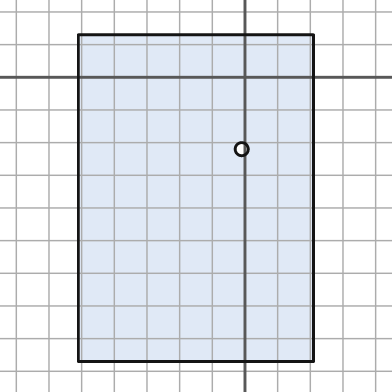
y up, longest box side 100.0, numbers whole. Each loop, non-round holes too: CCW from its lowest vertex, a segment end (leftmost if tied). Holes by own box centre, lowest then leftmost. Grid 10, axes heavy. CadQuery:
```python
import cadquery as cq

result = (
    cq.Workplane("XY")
    .moveTo(-51.0, -87.0)
    .lineTo(21.0, -87.0)
    .lineTo(21.0, 13.0)
    .lineTo(-51.0, 13.0)
    .close()
    .moveTo(-1.0, -22.0)
    .circle(2.0)
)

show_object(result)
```